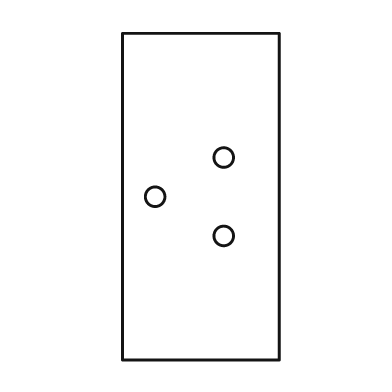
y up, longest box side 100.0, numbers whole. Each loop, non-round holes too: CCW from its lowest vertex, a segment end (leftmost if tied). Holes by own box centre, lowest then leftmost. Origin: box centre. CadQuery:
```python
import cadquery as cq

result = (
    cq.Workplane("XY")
    .moveTo(-24.0, -50.0)
    .lineTo(24.0, -50.0)
    .lineTo(24.0, 50.0)
    .lineTo(-24.0, 50.0)
    .close()
    .moveTo(7.0, -12.0)
    .circle(3.0)
    .moveTo(-14.0, 0.0)
    .circle(3.0)
    .moveTo(7.0, 12.0)
    .circle(3.0)
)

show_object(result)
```